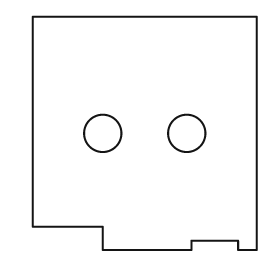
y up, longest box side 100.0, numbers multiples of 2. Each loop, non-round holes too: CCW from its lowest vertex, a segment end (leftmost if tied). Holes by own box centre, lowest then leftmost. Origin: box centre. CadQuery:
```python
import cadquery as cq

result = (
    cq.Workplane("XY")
    .moveTo(-18.0, -50.0)
    .lineTo(20.0, -50.0)
    .lineTo(20.0, -46.0)
    .lineTo(40.0, -46.0)
    .lineTo(40.0, -50.0)
    .lineTo(48.0, -50.0)
    .lineTo(48.0, 50.0)
    .lineTo(-48.0, 50.0)
    .lineTo(-48.0, -40.0)
    .lineTo(-18.0, -40.0)
    .close()
    .moveTo(-18.0, 0.0)
    .circle(8.0)
    .moveTo(18.0, 0.0)
    .circle(8.0)
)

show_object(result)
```